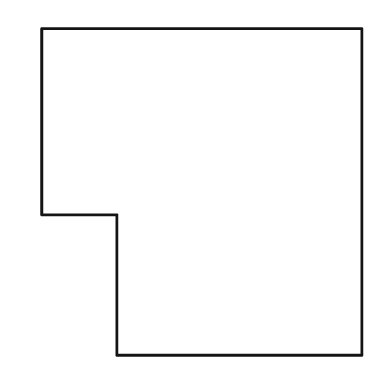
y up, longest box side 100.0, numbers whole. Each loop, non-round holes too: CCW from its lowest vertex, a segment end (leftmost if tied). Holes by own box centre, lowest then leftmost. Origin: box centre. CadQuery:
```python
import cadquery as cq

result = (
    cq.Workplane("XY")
    .moveTo(-26.0, -50.0)
    .lineTo(49.0, -50.0)
    .lineTo(49.0, 50.0)
    .lineTo(-49.0, 50.0)
    .lineTo(-49.0, -7.0)
    .lineTo(-26.0, -7.0)
    .close()
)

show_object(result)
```